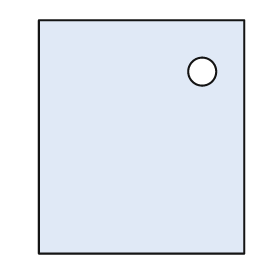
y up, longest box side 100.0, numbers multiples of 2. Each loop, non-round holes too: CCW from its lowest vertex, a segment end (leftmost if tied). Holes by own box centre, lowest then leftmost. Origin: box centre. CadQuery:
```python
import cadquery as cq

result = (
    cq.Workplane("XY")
    .moveTo(-44.0, -50.0)
    .lineTo(44.0, -50.0)
    .lineTo(44.0, 50.0)
    .lineTo(-44.0, 50.0)
    .close()
    .moveTo(26.0, 28.0)
    .circle(6.0)
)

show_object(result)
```